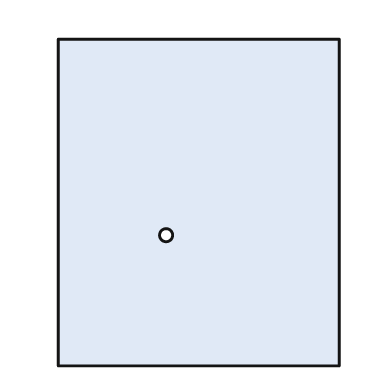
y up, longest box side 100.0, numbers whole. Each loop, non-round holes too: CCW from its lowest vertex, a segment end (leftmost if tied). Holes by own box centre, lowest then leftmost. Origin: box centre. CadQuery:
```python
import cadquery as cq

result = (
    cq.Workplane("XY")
    .moveTo(-43.0, -50.0)
    .lineTo(43.0, -50.0)
    .lineTo(43.0, 50.0)
    .lineTo(-43.0, 50.0)
    .close()
    .moveTo(-10.0, -10.0)
    .circle(2.0)
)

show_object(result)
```